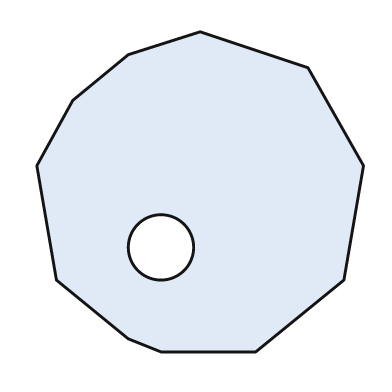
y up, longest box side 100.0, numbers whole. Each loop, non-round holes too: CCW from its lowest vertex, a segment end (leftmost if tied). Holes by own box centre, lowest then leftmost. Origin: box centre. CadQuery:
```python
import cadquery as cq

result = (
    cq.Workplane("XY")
    .moveTo(-12.0, -49.0)
    .lineTo(17.0, -49.0)
    .lineTo(44.0, -27.0)
    .lineTo(50.0, 8.0)
    .lineTo(33.0, 38.0)
    .lineTo(0.0, 49.0)
    .lineTo(-22.0, 42.0)
    .lineTo(-39.0, 28.0)
    .lineTo(-50.0, 8.0)
    .lineTo(-44.0, -27.0)
    .lineTo(-22.0, -45.0)
    .close()
    .moveTo(-12.0, -17.0)
    .circle(10.0)
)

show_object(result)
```